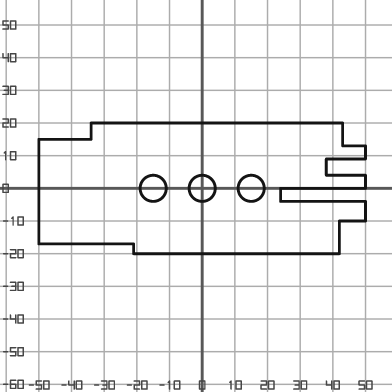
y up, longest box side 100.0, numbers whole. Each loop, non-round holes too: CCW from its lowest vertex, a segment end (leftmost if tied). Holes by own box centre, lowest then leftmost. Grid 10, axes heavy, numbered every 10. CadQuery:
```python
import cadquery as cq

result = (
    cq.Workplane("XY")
    .moveTo(-21.0, -20.0)
    .lineTo(42.0, -20.0)
    .lineTo(42.0, -10.0)
    .lineTo(50.0, -10.0)
    .lineTo(50.0, -4.0)
    .lineTo(24.0, -4.0)
    .lineTo(24.0, 0.0)
    .lineTo(50.0, 0.0)
    .lineTo(50.0, 4.0)
    .lineTo(38.0, 4.0)
    .lineTo(38.0, 9.0)
    .lineTo(50.0, 9.0)
    .lineTo(50.0, 13.0)
    .lineTo(43.0, 13.0)
    .lineTo(43.0, 20.0)
    .lineTo(-34.0, 20.0)
    .lineTo(-34.0, 15.0)
    .lineTo(-50.0, 15.0)
    .lineTo(-50.0, -17.0)
    .lineTo(-21.0, -17.0)
    .close()
    .moveTo(-15.0, 0.0)
    .circle(4.0)
    .moveTo(0.0, 0.0)
    .circle(4.0)
    .moveTo(15.0, 0.0)
    .circle(4.0)
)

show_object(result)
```